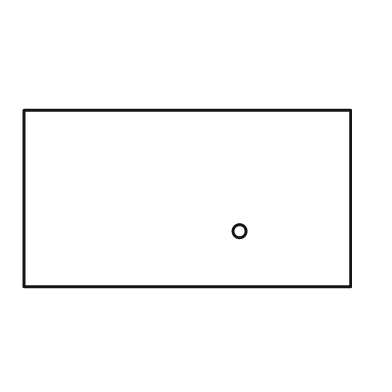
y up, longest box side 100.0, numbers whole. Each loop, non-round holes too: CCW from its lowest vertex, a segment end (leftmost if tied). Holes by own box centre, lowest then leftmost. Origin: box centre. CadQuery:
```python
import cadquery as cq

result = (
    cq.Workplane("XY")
    .moveTo(-50.0, -27.0)
    .lineTo(50.0, -27.0)
    .lineTo(50.0, 27.0)
    .lineTo(-50.0, 27.0)
    .close()
    .moveTo(16.0, -10.0)
    .circle(2.0)
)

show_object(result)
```